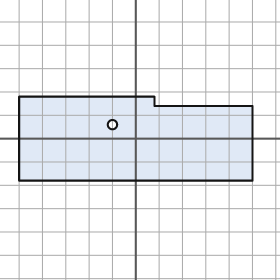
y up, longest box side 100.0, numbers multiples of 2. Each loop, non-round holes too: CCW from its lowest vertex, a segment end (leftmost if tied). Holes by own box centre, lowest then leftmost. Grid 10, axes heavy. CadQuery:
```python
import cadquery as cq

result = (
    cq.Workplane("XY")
    .moveTo(-50.0, -18.0)
    .lineTo(50.0, -18.0)
    .lineTo(50.0, 14.0)
    .lineTo(8.0, 14.0)
    .lineTo(8.0, 18.0)
    .lineTo(-50.0, 18.0)
    .close()
    .moveTo(-10.0, 6.0)
    .circle(2.0)
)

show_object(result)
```